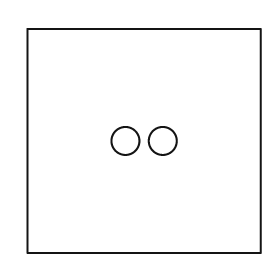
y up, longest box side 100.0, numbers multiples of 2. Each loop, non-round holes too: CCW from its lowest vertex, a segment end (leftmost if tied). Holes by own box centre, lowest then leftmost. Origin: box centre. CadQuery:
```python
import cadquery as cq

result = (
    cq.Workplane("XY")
    .moveTo(-50.0, -48.0)
    .lineTo(50.0, -48.0)
    .lineTo(50.0, 48.0)
    .lineTo(-50.0, 48.0)
    .close()
    .moveTo(-8.0, 0.0)
    .circle(6.0)
    .moveTo(8.0, 0.0)
    .circle(6.0)
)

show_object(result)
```